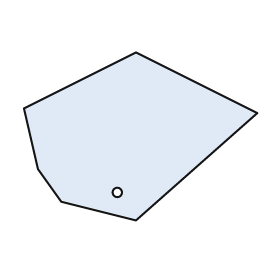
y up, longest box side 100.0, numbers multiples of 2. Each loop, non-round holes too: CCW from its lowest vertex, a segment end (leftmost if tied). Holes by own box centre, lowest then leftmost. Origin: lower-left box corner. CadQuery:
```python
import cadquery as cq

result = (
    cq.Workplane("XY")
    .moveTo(48.0, 0.0)
    .lineTo(100.0, 46.0)
    .lineTo(48.0, 72.0)
    .lineTo(0.0, 48.0)
    .lineTo(6.0, 22.0)
    .lineTo(16.0, 8.0)
    .close()
    .moveTo(40.0, 12.0)
    .circle(2.0)
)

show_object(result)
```